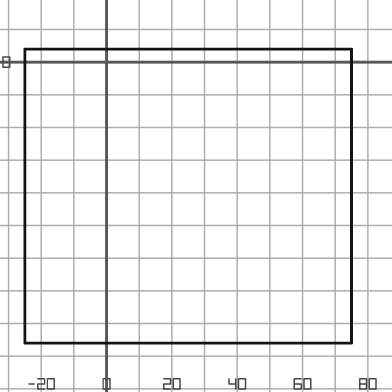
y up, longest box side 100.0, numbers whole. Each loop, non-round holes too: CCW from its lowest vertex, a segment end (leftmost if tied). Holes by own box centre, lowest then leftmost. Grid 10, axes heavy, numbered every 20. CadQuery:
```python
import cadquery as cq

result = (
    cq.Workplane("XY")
    .moveTo(-25.0, -86.0)
    .lineTo(75.0, -86.0)
    .lineTo(75.0, 4.0)
    .lineTo(-25.0, 4.0)
    .close()
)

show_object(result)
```